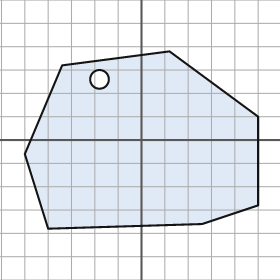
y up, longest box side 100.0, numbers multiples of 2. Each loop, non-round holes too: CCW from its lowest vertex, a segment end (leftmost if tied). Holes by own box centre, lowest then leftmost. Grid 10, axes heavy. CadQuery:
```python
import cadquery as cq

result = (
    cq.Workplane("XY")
    .moveTo(-40.0, -38.0)
    .lineTo(26.0, -36.0)
    .lineTo(50.0, -28.0)
    .lineTo(50.0, 10.0)
    .lineTo(12.0, 38.0)
    .lineTo(-34.0, 32.0)
    .lineTo(-50.0, -6.0)
    .close()
    .moveTo(-18.0, 26.0)
    .circle(4.0)
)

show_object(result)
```